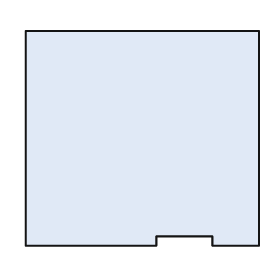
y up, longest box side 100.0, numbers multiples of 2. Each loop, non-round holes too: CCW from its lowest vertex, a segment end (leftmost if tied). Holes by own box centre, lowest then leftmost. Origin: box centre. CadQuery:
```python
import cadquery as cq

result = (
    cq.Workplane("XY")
    .moveTo(-50.0, -46.0)
    .lineTo(6.0, -46.0)
    .lineTo(6.0, -42.0)
    .lineTo(30.0, -42.0)
    .lineTo(30.0, -46.0)
    .lineTo(50.0, -46.0)
    .lineTo(50.0, 46.0)
    .lineTo(-50.0, 46.0)
    .close()
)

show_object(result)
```